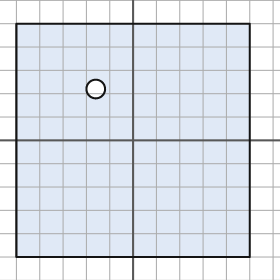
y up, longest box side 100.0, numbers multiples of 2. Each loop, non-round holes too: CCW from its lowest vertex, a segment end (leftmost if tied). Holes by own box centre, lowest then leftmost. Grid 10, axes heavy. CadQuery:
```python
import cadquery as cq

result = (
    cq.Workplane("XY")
    .moveTo(-50.0, -50.0)
    .lineTo(50.0, -50.0)
    .lineTo(50.0, 50.0)
    .lineTo(-50.0, 50.0)
    .close()
    .moveTo(-16.0, 22.0)
    .circle(4.0)
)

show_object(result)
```